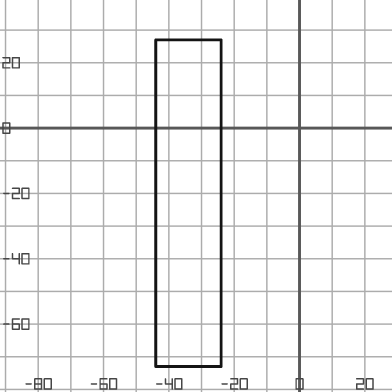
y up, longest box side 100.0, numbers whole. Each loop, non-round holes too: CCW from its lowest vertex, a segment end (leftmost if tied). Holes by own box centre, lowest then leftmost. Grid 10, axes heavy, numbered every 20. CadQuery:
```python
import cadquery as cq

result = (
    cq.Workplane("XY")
    .moveTo(-44.0, -73.0)
    .lineTo(-24.0, -73.0)
    .lineTo(-24.0, 27.0)
    .lineTo(-44.0, 27.0)
    .close()
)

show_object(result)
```